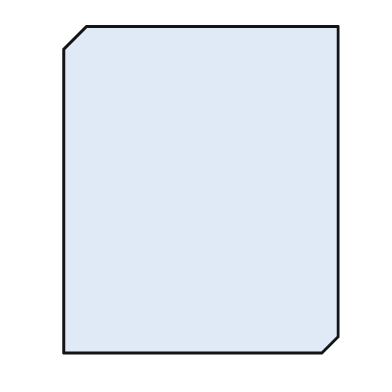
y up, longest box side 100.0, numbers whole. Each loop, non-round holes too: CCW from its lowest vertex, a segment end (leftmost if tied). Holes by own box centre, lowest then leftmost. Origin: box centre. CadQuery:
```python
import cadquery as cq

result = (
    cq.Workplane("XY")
    .moveTo(-42.0, -50.0)
    .lineTo(37.0, -50.0)
    .lineTo(42.0, -45.0)
    .lineTo(42.0, 50.0)
    .lineTo(-35.0, 50.0)
    .lineTo(-42.0, 43.0)
    .close()
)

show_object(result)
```